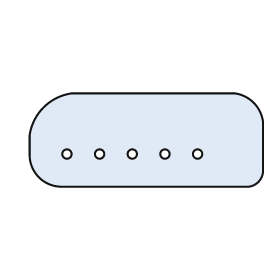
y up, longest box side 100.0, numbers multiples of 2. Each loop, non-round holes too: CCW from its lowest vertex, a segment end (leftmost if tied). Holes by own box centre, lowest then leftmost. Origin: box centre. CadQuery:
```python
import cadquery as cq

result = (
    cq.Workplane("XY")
    .moveTo(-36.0, -20.0)
    .lineTo(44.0, -20.0)
    .threePointArc((48.0, -18.0), (50.0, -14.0))
    .lineTo(50.0, 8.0)
    .threePointArc((46.0, 16.0), (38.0, 20.0))
    .lineTo(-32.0, 20.0)
    .threePointArc((-44.0, 14.0), (-50.0, 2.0))
    .lineTo(-50.0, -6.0)
    .threePointArc((-46.0, -16.0), (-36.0, -20.0))
    .close()
    .moveTo(-34.0, -6.0)
    .circle(2.0)
    .moveTo(-20.0, -6.0)
    .circle(2.0)
    .moveTo(-6.0, -6.0)
    .circle(2.0)
    .moveTo(8.0, -6.0)
    .circle(2.0)
    .moveTo(22.0, -6.0)
    .circle(2.0)
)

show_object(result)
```